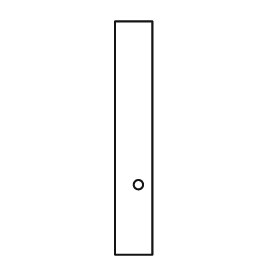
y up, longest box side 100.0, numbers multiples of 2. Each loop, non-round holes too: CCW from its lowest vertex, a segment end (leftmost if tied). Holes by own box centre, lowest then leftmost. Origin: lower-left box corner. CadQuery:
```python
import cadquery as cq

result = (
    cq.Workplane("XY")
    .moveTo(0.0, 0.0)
    .lineTo(16.0, 0.0)
    .lineTo(16.0, 100.0)
    .lineTo(0.0, 100.0)
    .close()
    .moveTo(10.0, 30.0)
    .circle(2.0)
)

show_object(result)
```